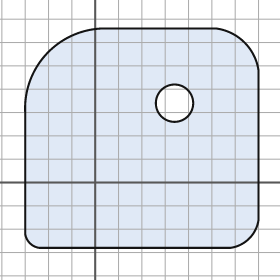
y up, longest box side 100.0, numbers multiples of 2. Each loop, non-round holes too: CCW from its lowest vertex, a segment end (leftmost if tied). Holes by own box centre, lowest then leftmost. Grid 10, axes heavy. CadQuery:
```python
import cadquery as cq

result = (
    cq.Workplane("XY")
    .moveTo(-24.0, -28.0)
    .lineTo(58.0, -28.0)
    .threePointArc((66.0, -24.0), (70.0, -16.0))
    .lineTo(70.0, 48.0)
    .threePointArc((64.0, 60.0), (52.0, 66.0))
    .lineTo(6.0, 66.0)
    .threePointArc((-20.0, 56.0), (-30.0, 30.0))
    .lineTo(-30.0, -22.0)
    .threePointArc((-28.0, -26.0), (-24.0, -28.0))
    .close()
    .moveTo(34.0, 34.0)
    .circle(8.0)
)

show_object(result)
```